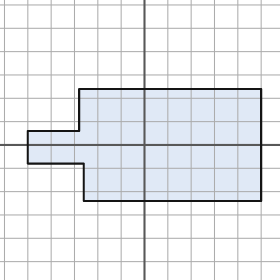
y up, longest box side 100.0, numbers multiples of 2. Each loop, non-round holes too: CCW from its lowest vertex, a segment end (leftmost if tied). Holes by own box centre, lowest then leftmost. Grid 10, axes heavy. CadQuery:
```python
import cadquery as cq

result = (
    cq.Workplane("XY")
    .moveTo(-26.0, -24.0)
    .lineTo(50.0, -24.0)
    .lineTo(50.0, 24.0)
    .lineTo(-28.0, 24.0)
    .lineTo(-28.0, 6.0)
    .lineTo(-50.0, 6.0)
    .lineTo(-50.0, -8.0)
    .lineTo(-26.0, -8.0)
    .close()
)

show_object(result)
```